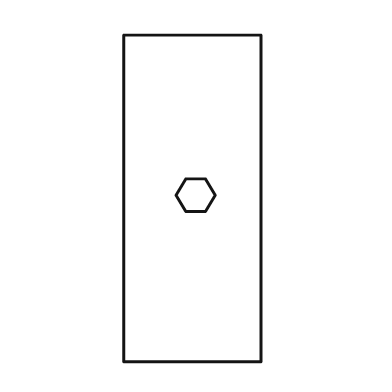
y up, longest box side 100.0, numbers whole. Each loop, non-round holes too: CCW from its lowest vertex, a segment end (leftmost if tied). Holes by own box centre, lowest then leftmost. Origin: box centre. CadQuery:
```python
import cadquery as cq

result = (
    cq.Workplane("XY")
    .moveTo(-21.0, -50.0)
    .lineTo(21.0, -50.0)
    .lineTo(21.0, 50.0)
    .lineTo(-21.0, 50.0)
    .close()
    .moveTo(-2.0, -4.0)
    .lineTo(4.0, -4.0)
    .lineTo(7.0, 1.0)
    .lineTo(4.0, 6.0)
    .lineTo(-2.0, 6.0)
    .lineTo(-5.0, 1.0)
    .close()
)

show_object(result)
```